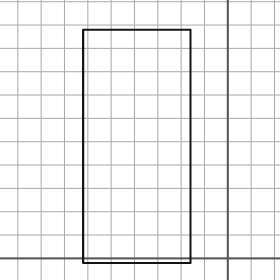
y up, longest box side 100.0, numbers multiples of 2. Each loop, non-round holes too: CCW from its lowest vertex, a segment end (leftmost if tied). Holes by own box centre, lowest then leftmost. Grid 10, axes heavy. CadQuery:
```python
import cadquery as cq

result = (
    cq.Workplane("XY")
    .moveTo(-62.0, -2.0)
    .lineTo(-16.0, -2.0)
    .lineTo(-16.0, 98.0)
    .lineTo(-62.0, 98.0)
    .close()
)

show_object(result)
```